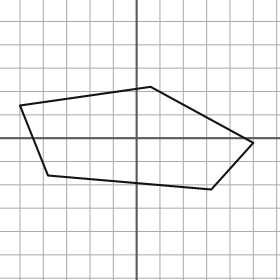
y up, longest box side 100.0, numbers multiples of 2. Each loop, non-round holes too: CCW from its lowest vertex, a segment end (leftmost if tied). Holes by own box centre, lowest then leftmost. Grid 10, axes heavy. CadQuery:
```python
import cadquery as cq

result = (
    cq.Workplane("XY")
    .moveTo(32.0, -22.0)
    .lineTo(50.0, -2.0)
    .lineTo(6.0, 22.0)
    .lineTo(-50.0, 14.0)
    .lineTo(-38.0, -16.0)
    .close()
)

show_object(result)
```